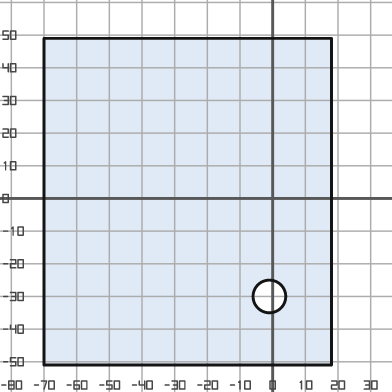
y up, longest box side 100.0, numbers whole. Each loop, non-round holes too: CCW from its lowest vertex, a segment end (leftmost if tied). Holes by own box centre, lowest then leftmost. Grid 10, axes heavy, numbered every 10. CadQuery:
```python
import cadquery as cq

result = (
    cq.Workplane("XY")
    .moveTo(-70.0, -51.0)
    .lineTo(18.0, -51.0)
    .lineTo(18.0, 49.0)
    .lineTo(-70.0, 49.0)
    .close()
    .moveTo(-1.0, -30.0)
    .circle(5.0)
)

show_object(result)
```